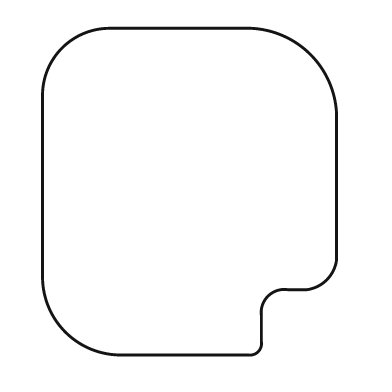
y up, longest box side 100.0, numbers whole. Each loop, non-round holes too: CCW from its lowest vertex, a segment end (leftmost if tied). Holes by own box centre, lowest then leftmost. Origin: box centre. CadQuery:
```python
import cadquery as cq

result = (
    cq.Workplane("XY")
    .moveTo(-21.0, -50.0)
    .lineTo(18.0, -50.0)
    .threePointArc((21.0, -49.0), (22.0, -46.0))
    .lineTo(22.0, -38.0)
    .threePointArc((24.0, -32.0), (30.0, -30.0))
    .lineTo(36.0, -30.0)
    .threePointArc((42.0, -27.0), (45.0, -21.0))
    .lineTo(45.0, 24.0)
    .threePointArc((37.0, 42.0), (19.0, 50.0))
    .lineTo(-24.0, 50.0)
    .threePointArc((-39.0, 44.0), (-45.0, 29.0))
    .lineTo(-45.0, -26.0)
    .threePointArc((-38.0, -43.0), (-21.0, -50.0))
    .close()
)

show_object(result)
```